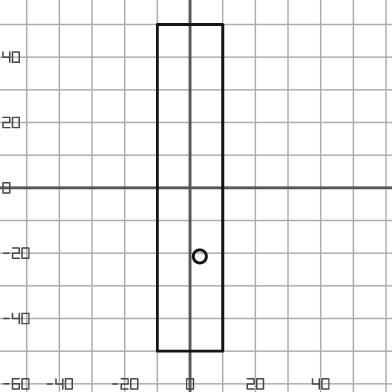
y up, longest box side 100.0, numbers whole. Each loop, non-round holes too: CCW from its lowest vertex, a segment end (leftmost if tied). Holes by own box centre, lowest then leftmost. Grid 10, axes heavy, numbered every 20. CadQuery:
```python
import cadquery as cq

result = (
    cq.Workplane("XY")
    .moveTo(-10.0, -50.0)
    .lineTo(10.0, -50.0)
    .lineTo(10.0, 50.0)
    .lineTo(-10.0, 50.0)
    .close()
    .moveTo(3.0, -21.0)
    .circle(2.0)
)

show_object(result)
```